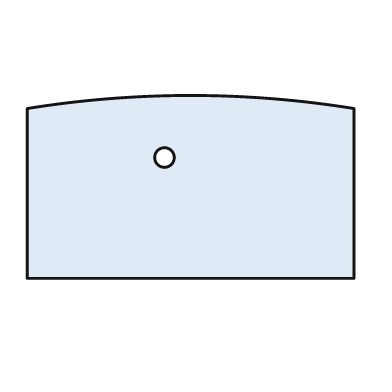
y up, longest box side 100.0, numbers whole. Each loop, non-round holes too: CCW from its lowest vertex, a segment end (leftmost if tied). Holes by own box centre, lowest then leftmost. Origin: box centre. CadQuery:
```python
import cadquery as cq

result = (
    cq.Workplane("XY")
    .moveTo(-50.0, -28.0)
    .lineTo(50.0, -28.0)
    .lineTo(50.0, 24.0)
    .threePointArc((0.0, 28.0), (-50.0, 24.0))
    .close()
    .moveTo(-8.0, 9.0)
    .circle(3.0)
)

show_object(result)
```